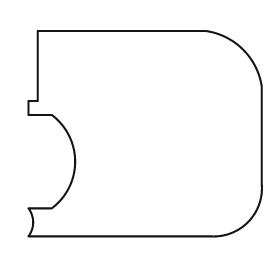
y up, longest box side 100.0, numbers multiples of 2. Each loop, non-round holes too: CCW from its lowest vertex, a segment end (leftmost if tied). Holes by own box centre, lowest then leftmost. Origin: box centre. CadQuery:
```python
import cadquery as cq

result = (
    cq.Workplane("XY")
    .moveTo(-50.0, -44.0)
    .lineTo(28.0, -44.0)
    .threePointArc((44.0, -38.0), (50.0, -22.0))
    .lineTo(50.0, 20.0)
    .threePointArc((42.0, 36.0), (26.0, 44.0))
    .lineTo(-46.0, 44.0)
    .lineTo(-46.0, 14.0)
    .lineTo(-50.0, 14.0)
    .lineTo(-50.0, 8.0)
    .lineTo(-40.0, 8.0)
    .threePointArc((-30.0, -12.0), (-40.0, -32.0))
    .lineTo(-50.0, -32.0)
    .threePointArc((-48.0, -38.0), (-50.0, -44.0))
    .close()
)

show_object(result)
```